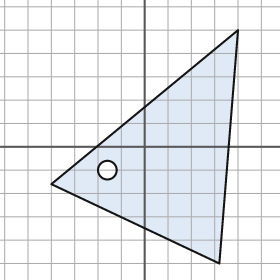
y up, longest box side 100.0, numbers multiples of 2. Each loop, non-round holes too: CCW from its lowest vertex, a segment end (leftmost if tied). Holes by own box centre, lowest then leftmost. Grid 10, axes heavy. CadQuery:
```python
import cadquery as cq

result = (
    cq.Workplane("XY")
    .moveTo(32.0, -50.0)
    .lineTo(40.0, 50.0)
    .lineTo(-40.0, -16.0)
    .close()
    .moveTo(-16.0, -10.0)
    .circle(4.0)
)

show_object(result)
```